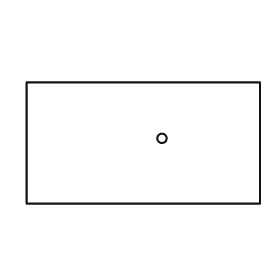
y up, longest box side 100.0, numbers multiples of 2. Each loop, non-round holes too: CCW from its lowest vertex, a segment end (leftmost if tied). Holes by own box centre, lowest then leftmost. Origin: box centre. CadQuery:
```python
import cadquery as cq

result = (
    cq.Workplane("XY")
    .moveTo(-50.0, -26.0)
    .lineTo(50.0, -26.0)
    .lineTo(50.0, 26.0)
    .lineTo(-50.0, 26.0)
    .close()
    .moveTo(8.0, 2.0)
    .circle(2.0)
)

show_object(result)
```